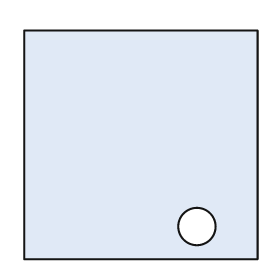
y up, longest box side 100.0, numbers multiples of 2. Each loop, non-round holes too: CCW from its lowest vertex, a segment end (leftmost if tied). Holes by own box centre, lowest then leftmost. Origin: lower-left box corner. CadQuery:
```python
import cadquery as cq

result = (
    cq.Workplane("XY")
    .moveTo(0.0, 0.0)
    .lineTo(100.0, 0.0)
    .lineTo(100.0, 98.0)
    .lineTo(0.0, 98.0)
    .close()
    .moveTo(74.0, 14.0)
    .circle(8.0)
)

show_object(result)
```